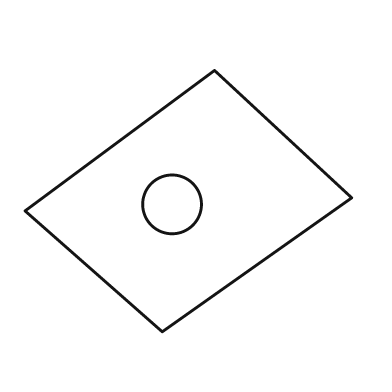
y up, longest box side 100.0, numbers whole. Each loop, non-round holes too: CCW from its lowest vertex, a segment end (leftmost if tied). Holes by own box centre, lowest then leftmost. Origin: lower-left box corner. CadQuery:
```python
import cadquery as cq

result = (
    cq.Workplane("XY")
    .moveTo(42.0, 0.0)
    .lineTo(100.0, 41.0)
    .lineTo(58.0, 80.0)
    .lineTo(0.0, 37.0)
    .close()
    .moveTo(45.0, 39.0)
    .circle(9.0)
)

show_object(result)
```